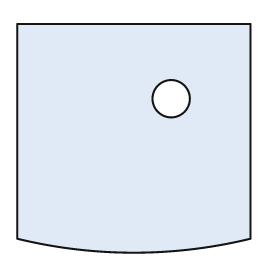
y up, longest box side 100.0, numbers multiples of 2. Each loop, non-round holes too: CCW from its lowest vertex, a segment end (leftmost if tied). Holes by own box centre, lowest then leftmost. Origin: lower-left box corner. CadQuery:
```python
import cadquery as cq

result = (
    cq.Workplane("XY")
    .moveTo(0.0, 6.0)
    .threePointArc((50.0, 0.0), (100.0, 6.0))
    .lineTo(100.0, 98.0)
    .lineTo(0.0, 98.0)
    .close()
    .moveTo(66.0, 66.0)
    .circle(8.0)
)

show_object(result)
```